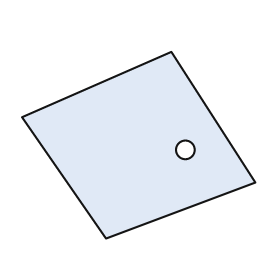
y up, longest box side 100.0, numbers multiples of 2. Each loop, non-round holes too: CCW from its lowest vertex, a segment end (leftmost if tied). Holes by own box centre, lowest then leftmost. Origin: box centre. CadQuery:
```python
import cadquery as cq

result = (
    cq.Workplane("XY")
    .moveTo(-14.0, -40.0)
    .lineTo(50.0, -16.0)
    .lineTo(14.0, 40.0)
    .lineTo(-50.0, 12.0)
    .close()
    .moveTo(20.0, -2.0)
    .circle(4.0)
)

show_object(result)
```